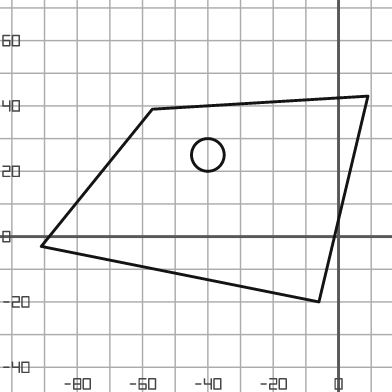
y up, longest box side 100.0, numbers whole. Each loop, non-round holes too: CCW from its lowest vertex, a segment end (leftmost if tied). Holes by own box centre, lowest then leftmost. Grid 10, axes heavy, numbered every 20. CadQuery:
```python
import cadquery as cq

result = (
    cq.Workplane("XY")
    .moveTo(-6.0, -20.0)
    .lineTo(9.0, 43.0)
    .lineTo(-57.0, 39.0)
    .lineTo(-91.0, -3.0)
    .close()
    .moveTo(-40.0, 25.0)
    .circle(5.0)
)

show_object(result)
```